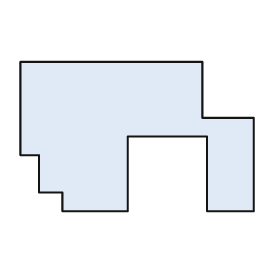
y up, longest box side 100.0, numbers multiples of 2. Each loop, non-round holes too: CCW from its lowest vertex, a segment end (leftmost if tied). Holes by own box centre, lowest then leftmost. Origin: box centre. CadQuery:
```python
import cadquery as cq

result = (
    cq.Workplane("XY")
    .moveTo(-32.0, -32.0)
    .lineTo(-4.0, -32.0)
    .lineTo(-4.0, 0.0)
    .lineTo(30.0, 0.0)
    .lineTo(30.0, -32.0)
    .lineTo(50.0, -32.0)
    .lineTo(50.0, 8.0)
    .lineTo(28.0, 8.0)
    .lineTo(28.0, 32.0)
    .lineTo(-50.0, 32.0)
    .lineTo(-50.0, -8.0)
    .lineTo(-42.0, -8.0)
    .lineTo(-42.0, -24.0)
    .lineTo(-32.0, -24.0)
    .close()
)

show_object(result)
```